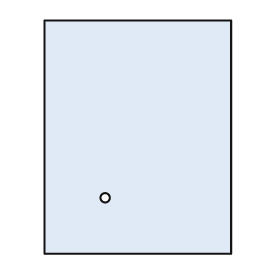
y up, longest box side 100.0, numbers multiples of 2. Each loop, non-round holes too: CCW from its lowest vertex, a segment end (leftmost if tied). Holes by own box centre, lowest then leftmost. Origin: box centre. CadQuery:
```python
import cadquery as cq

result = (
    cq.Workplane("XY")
    .moveTo(-40.0, -50.0)
    .lineTo(40.0, -50.0)
    .lineTo(40.0, 50.0)
    .lineTo(-40.0, 50.0)
    .close()
    .moveTo(-14.0, -26.0)
    .circle(2.0)
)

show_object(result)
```